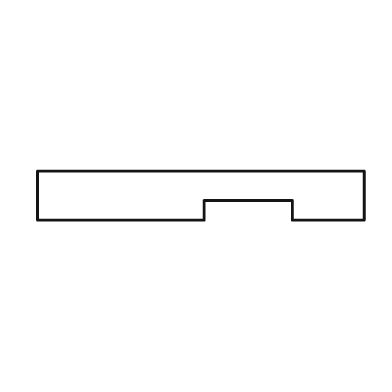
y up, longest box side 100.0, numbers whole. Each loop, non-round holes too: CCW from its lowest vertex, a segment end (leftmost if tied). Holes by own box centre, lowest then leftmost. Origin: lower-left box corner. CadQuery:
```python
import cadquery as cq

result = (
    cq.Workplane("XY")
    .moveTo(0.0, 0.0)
    .lineTo(51.0, 0.0)
    .lineTo(51.0, 6.0)
    .lineTo(78.0, 6.0)
    .lineTo(78.0, 0.0)
    .lineTo(100.0, 0.0)
    .lineTo(100.0, 15.0)
    .lineTo(0.0, 15.0)
    .close()
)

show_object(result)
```